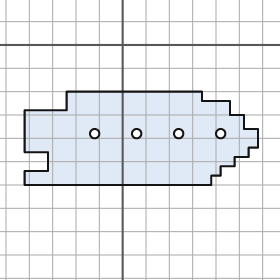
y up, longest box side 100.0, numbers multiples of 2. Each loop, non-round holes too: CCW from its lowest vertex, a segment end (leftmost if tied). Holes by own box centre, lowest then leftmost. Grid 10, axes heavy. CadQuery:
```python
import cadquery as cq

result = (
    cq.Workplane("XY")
    .moveTo(-42.0, -60.0)
    .lineTo(38.0, -60.0)
    .lineTo(38.0, -56.0)
    .lineTo(42.0, -56.0)
    .lineTo(42.0, -52.0)
    .lineTo(48.0, -52.0)
    .lineTo(48.0, -48.0)
    .lineTo(54.0, -48.0)
    .lineTo(54.0, -44.0)
    .lineTo(58.0, -44.0)
    .lineTo(58.0, -36.0)
    .lineTo(52.0, -36.0)
    .lineTo(52.0, -30.0)
    .lineTo(46.0, -30.0)
    .lineTo(46.0, -24.0)
    .lineTo(34.0, -24.0)
    .lineTo(34.0, -20.0)
    .lineTo(-24.0, -20.0)
    .lineTo(-24.0, -28.0)
    .lineTo(-42.0, -28.0)
    .lineTo(-42.0, -46.0)
    .lineTo(-32.0, -46.0)
    .lineTo(-32.0, -54.0)
    .lineTo(-42.0, -54.0)
    .close()
    .moveTo(-12.0, -38.0)
    .circle(2.0)
    .moveTo(6.0, -38.0)
    .circle(2.0)
    .moveTo(24.0, -38.0)
    .circle(2.0)
    .moveTo(42.0, -38.0)
    .circle(2.0)
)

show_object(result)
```